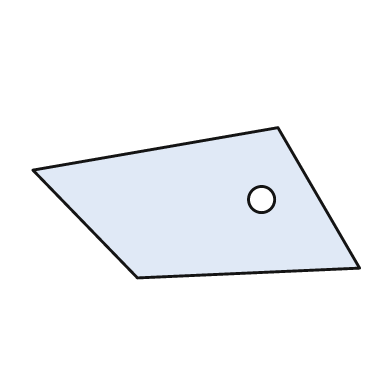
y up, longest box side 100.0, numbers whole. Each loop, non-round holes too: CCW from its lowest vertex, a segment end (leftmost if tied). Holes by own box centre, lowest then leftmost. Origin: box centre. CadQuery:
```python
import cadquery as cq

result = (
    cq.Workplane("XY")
    .moveTo(-18.0, -23.0)
    .lineTo(50.0, -20.0)
    .lineTo(25.0, 23.0)
    .lineTo(-50.0, 10.0)
    .close()
    .moveTo(20.0, 1.0)
    .circle(4.0)
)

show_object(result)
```